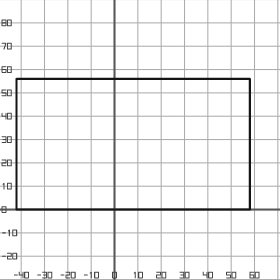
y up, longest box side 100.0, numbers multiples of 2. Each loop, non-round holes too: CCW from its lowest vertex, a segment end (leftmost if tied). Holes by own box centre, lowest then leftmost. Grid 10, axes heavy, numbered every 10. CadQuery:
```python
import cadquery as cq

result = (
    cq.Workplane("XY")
    .moveTo(-42.0, 0.0)
    .lineTo(58.0, 0.0)
    .lineTo(58.0, 56.0)
    .lineTo(-42.0, 56.0)
    .close()
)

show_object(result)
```